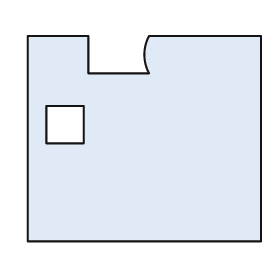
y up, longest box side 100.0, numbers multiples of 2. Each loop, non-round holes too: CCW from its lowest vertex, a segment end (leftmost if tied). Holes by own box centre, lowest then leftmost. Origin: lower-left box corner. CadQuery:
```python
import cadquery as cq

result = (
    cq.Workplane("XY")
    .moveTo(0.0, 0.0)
    .lineTo(100.0, 0.0)
    .lineTo(100.0, 88.0)
    .lineTo(52.0, 88.0)
    .threePointArc((50.0, 80.0), (52.0, 72.0))
    .lineTo(26.0, 72.0)
    .lineTo(26.0, 88.0)
    .lineTo(0.0, 88.0)
    .close()
    .moveTo(8.0, 42.0)
    .lineTo(24.0, 42.0)
    .lineTo(24.0, 58.0)
    .lineTo(8.0, 58.0)
    .close()
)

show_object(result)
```